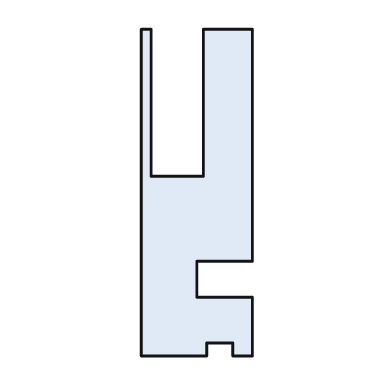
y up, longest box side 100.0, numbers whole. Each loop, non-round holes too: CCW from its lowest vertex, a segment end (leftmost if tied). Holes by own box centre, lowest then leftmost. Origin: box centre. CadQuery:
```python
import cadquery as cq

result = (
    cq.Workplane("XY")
    .moveTo(-17.0, -50.0)
    .lineTo(3.0, -50.0)
    .lineTo(3.0, -46.0)
    .lineTo(11.0, -46.0)
    .lineTo(11.0, -50.0)
    .lineTo(17.0, -50.0)
    .lineTo(17.0, -32.0)
    .lineTo(0.0, -32.0)
    .lineTo(0.0, -21.0)
    .lineTo(17.0, -21.0)
    .lineTo(17.0, 50.0)
    .lineTo(2.0, 50.0)
    .lineTo(2.0, 5.0)
    .lineTo(-14.0, 5.0)
    .lineTo(-14.0, 50.0)
    .lineTo(-17.0, 50.0)
    .close()
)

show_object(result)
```